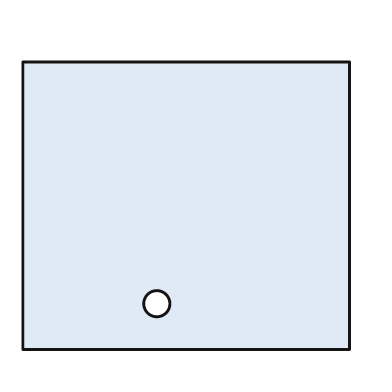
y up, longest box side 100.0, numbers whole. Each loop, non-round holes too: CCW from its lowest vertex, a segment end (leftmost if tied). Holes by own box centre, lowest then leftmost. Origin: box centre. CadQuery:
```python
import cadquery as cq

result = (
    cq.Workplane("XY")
    .moveTo(-50.0, -44.0)
    .lineTo(50.0, -44.0)
    .lineTo(50.0, 44.0)
    .lineTo(-50.0, 44.0)
    .close()
    .moveTo(-9.0, -30.0)
    .circle(4.0)
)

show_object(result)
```